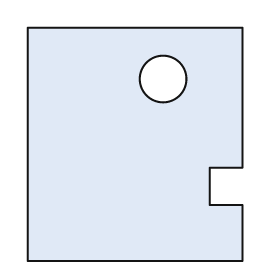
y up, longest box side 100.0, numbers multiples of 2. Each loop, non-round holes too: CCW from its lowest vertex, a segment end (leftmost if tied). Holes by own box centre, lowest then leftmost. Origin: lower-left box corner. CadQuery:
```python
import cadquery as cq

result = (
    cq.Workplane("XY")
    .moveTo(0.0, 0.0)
    .lineTo(92.0, 0.0)
    .lineTo(92.0, 24.0)
    .lineTo(78.0, 24.0)
    .lineTo(78.0, 40.0)
    .lineTo(92.0, 40.0)
    .lineTo(92.0, 100.0)
    .lineTo(0.0, 100.0)
    .close()
    .moveTo(58.0, 78.0)
    .circle(10.0)
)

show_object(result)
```